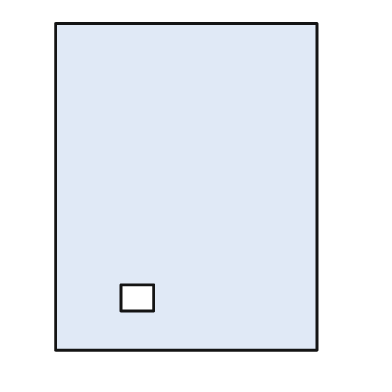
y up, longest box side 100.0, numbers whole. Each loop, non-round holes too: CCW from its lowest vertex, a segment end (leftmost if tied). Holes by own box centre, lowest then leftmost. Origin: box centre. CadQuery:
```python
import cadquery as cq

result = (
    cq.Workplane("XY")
    .moveTo(-40.0, -50.0)
    .lineTo(40.0, -50.0)
    .lineTo(40.0, 50.0)
    .lineTo(-40.0, 50.0)
    .close()
    .moveTo(-20.0, -38.0)
    .lineTo(-10.0, -38.0)
    .lineTo(-10.0, -30.0)
    .lineTo(-20.0, -30.0)
    .close()
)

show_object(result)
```